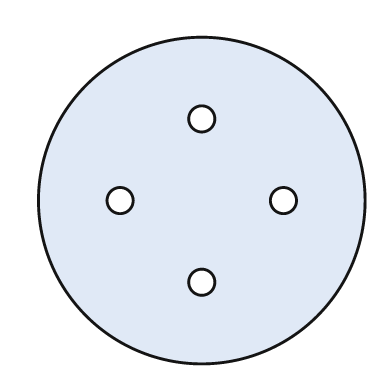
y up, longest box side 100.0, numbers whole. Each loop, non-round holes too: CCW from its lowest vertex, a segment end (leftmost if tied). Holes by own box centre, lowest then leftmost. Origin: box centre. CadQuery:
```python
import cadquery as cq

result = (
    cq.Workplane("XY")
    .moveTo(0.0, 0.0)
    .circle(50.0)
    .moveTo(0.0, -25.0)
    .circle(4.0)
    .moveTo(-25.0, 0.0)
    .circle(4.0)
    .moveTo(25.0, 0.0)
    .circle(4.0)
    .moveTo(0.0, 25.0)
    .circle(4.0)
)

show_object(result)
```